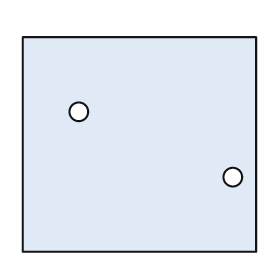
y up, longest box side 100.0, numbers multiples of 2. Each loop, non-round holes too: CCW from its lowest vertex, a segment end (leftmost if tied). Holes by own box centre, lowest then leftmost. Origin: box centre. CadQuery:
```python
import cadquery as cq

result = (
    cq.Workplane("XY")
    .moveTo(-50.0, -46.0)
    .lineTo(50.0, -46.0)
    .lineTo(50.0, 46.0)
    .lineTo(-50.0, 46.0)
    .close()
    .moveTo(40.0, -14.0)
    .circle(4.0)
    .moveTo(-26.0, 14.0)
    .circle(4.0)
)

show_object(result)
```